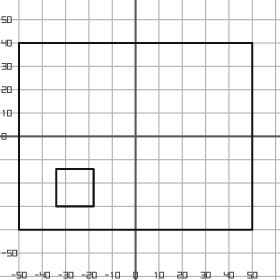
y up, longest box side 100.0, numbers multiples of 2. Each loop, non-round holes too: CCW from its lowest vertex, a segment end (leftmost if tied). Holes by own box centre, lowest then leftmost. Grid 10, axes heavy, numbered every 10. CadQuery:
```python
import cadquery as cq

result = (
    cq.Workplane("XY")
    .moveTo(-50.0, -40.0)
    .lineTo(50.0, -40.0)
    .lineTo(50.0, 40.0)
    .lineTo(-50.0, 40.0)
    .close()
    .moveTo(-34.0, -30.0)
    .lineTo(-18.0, -30.0)
    .lineTo(-18.0, -14.0)
    .lineTo(-34.0, -14.0)
    .close()
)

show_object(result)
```